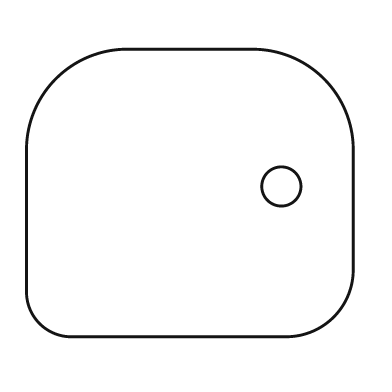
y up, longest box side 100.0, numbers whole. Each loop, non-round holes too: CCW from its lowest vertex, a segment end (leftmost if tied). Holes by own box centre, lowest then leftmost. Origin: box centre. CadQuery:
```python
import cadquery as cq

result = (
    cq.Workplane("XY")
    .moveTo(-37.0, -44.0)
    .lineTo(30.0, -44.0)
    .threePointArc((44.0, -38.0), (50.0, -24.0))
    .lineTo(50.0, 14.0)
    .threePointArc((41.0, 35.0), (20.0, 44.0))
    .lineTo(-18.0, 44.0)
    .threePointArc((-41.0, 35.0), (-50.0, 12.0))
    .lineTo(-50.0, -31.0)
    .threePointArc((-46.0, -40.0), (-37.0, -44.0))
    .close()
    .moveTo(28.0, 2.0)
    .circle(6.0)
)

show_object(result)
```